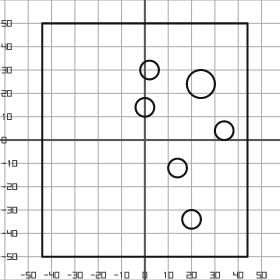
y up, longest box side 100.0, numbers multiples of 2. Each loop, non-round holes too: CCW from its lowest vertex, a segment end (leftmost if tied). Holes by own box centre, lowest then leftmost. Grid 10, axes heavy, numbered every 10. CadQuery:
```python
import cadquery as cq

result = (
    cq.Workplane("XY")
    .moveTo(-44.0, -50.0)
    .lineTo(44.0, -50.0)
    .lineTo(44.0, 50.0)
    .lineTo(-44.0, 50.0)
    .close()
    .moveTo(20.0, -34.0)
    .circle(4.0)
    .moveTo(14.0, -12.0)
    .circle(4.0)
    .moveTo(34.0, 4.0)
    .circle(4.0)
    .moveTo(0.0, 14.0)
    .circle(4.0)
    .moveTo(24.0, 24.0)
    .circle(6.0)
    .moveTo(2.0, 30.0)
    .circle(4.0)
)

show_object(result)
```